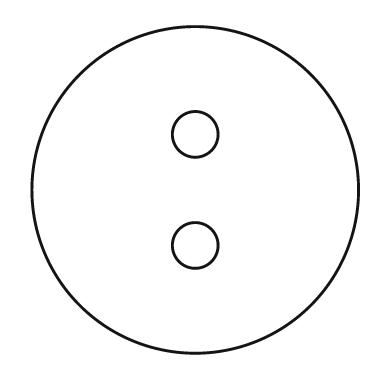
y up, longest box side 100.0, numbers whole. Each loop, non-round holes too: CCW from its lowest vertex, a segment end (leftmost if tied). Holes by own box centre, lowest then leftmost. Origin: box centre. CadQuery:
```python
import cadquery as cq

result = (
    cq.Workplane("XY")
    .moveTo(0.0, 0.0)
    .circle(50.0)
    .moveTo(0.0, -17.0)
    .circle(7.0)
    .moveTo(0.0, 17.0)
    .circle(7.0)
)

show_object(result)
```